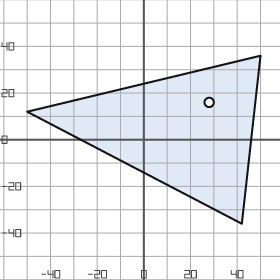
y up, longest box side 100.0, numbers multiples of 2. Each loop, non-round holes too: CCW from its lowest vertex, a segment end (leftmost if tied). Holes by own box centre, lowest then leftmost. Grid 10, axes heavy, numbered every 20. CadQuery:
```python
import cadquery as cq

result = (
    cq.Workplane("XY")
    .moveTo(42.0, -36.0)
    .lineTo(50.0, 36.0)
    .lineTo(-50.0, 12.0)
    .close()
    .moveTo(28.0, 16.0)
    .circle(2.0)
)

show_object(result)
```